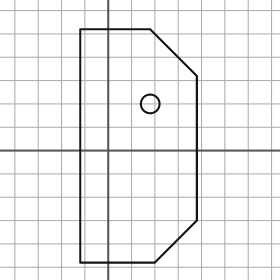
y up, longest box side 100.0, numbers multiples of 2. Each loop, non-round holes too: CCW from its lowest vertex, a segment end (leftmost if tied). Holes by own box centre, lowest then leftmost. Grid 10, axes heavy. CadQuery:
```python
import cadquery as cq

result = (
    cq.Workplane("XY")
    .moveTo(-12.0, -48.0)
    .lineTo(20.0, -48.0)
    .lineTo(38.0, -30.0)
    .lineTo(38.0, 32.0)
    .lineTo(18.0, 52.0)
    .lineTo(-12.0, 52.0)
    .close()
    .moveTo(18.0, 20.0)
    .circle(4.0)
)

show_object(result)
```